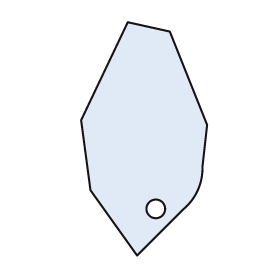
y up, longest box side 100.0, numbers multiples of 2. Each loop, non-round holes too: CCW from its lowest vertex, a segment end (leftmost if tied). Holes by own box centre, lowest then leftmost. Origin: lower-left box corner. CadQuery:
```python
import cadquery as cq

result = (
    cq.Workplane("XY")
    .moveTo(24.0, 0.0)
    .lineTo(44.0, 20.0)
    .threePointArc((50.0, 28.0), (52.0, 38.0))
    .lineTo(54.0, 56.0)
    .lineTo(38.0, 96.0)
    .lineTo(20.0, 100.0)
    .lineTo(0.0, 58.0)
    .lineTo(4.0, 28.0)
    .close()
    .moveTo(32.0, 20.0)
    .circle(4.0)
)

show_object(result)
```